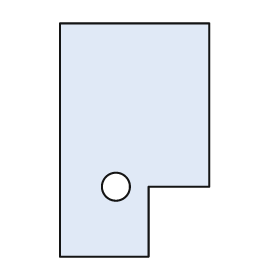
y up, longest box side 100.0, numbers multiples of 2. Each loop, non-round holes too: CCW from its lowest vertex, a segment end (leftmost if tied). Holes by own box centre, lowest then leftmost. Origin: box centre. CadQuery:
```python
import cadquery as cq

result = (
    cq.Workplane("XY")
    .moveTo(-32.0, -50.0)
    .lineTo(6.0, -50.0)
    .lineTo(6.0, -20.0)
    .lineTo(32.0, -20.0)
    .lineTo(32.0, 50.0)
    .lineTo(-32.0, 50.0)
    .close()
    .moveTo(-8.0, -20.0)
    .circle(6.0)
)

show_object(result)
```